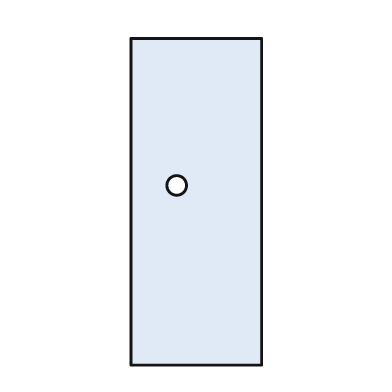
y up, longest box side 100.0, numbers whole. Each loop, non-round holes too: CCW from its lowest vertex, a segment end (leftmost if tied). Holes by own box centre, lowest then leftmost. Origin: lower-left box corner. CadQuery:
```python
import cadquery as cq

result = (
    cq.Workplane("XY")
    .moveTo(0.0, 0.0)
    .lineTo(40.0, 0.0)
    .lineTo(40.0, 100.0)
    .lineTo(0.0, 100.0)
    .close()
    .moveTo(14.0, 55.0)
    .circle(3.0)
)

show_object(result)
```